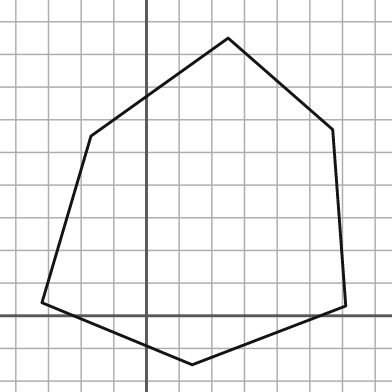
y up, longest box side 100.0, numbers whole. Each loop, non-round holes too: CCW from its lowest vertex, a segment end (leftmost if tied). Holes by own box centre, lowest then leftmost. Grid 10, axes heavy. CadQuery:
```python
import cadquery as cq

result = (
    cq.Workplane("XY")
    .moveTo(14.0, -15.0)
    .lineTo(61.0, 3.0)
    .lineTo(57.0, 57.0)
    .lineTo(25.0, 85.0)
    .lineTo(-17.0, 55.0)
    .lineTo(-32.0, 4.0)
    .close()
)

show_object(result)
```